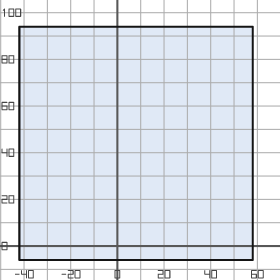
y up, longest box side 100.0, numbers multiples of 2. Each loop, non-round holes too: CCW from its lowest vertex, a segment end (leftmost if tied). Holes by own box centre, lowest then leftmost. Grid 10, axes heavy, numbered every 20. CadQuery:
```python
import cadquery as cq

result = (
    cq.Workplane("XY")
    .moveTo(-42.0, -6.0)
    .lineTo(58.0, -6.0)
    .lineTo(58.0, 94.0)
    .lineTo(-42.0, 94.0)
    .close()
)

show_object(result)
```